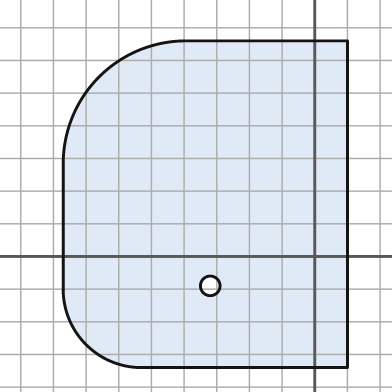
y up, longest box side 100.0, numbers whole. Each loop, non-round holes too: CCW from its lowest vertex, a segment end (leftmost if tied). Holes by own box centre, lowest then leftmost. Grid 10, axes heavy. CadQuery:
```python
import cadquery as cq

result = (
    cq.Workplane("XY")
    .moveTo(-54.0, -34.0)
    .lineTo(10.0, -34.0)
    .lineTo(10.0, 66.0)
    .lineTo(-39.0, 66.0)
    .threePointArc((-66.0, 55.0), (-77.0, 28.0))
    .lineTo(-77.0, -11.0)
    .threePointArc((-70.0, -27.0), (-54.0, -34.0))
    .close()
    .moveTo(-32.0, -9.0)
    .circle(3.0)
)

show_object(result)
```